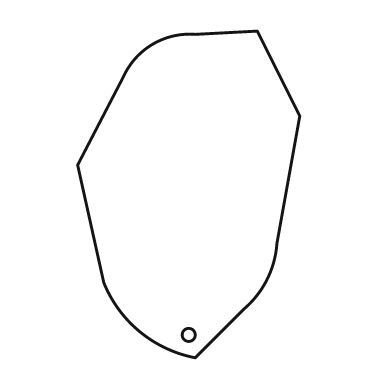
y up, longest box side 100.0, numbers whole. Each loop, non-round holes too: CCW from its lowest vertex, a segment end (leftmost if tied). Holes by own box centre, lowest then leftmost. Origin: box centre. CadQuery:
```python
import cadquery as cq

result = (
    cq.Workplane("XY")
    .moveTo(2.0, -50.0)
    .lineTo(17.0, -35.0)
    .threePointArc((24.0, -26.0), (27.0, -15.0))
    .lineTo(34.0, 24.0)
    .lineTo(21.0, 50.0)
    .lineTo(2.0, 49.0)
    .threePointArc((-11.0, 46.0), (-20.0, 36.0))
    .lineTo(-34.0, 9.0)
    .lineTo(-26.0, -27.0)
    .threePointArc((-15.0, -42.0), (2.0, -50.0))
    .close()
    .moveTo(0.0, -43.0)
    .circle(2.0)
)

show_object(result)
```